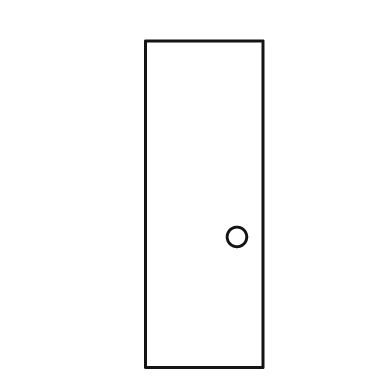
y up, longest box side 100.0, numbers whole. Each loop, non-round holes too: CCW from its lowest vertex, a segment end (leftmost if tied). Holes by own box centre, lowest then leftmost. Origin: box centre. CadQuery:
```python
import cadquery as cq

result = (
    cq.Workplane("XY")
    .moveTo(-18.0, -50.0)
    .lineTo(18.0, -50.0)
    .lineTo(18.0, 50.0)
    .lineTo(-18.0, 50.0)
    .close()
    .moveTo(10.0, -10.0)
    .circle(3.0)
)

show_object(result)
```